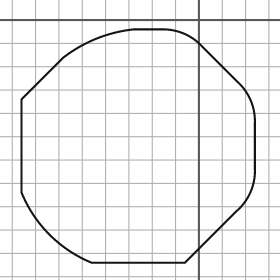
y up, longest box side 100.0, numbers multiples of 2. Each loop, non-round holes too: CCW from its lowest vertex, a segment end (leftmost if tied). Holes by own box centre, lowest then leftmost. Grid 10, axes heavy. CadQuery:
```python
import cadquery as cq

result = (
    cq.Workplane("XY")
    .moveTo(-46.0, -104.0)
    .lineTo(-6.0, -104.0)
    .lineTo(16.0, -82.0)
    .threePointArc((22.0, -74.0), (24.0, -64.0))
    .lineTo(24.0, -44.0)
    .threePointArc((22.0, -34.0), (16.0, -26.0))
    .lineTo(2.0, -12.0)
    .threePointArc((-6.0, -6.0), (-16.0, -4.0))
    .lineTo(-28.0, -4.0)
    .threePointArc((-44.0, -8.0), (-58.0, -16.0))
    .lineTo(-76.0, -34.0)
    .lineTo(-76.0, -74.0)
    .threePointArc((-64.0, -92.0), (-46.0, -104.0))
    .close()
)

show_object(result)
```